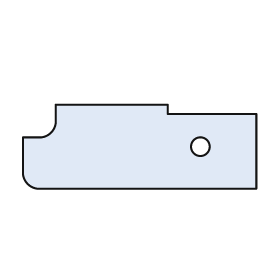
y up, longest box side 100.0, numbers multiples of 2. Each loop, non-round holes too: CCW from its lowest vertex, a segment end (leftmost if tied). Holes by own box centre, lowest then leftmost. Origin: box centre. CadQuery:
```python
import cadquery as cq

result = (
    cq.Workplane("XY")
    .moveTo(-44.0, -18.0)
    .lineTo(50.0, -18.0)
    .lineTo(50.0, 14.0)
    .lineTo(12.0, 14.0)
    .lineTo(12.0, 18.0)
    .lineTo(-36.0, 18.0)
    .lineTo(-36.0, 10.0)
    .threePointArc((-38.0, 6.0), (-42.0, 4.0))
    .lineTo(-50.0, 4.0)
    .lineTo(-50.0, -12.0)
    .threePointArc((-48.0, -16.0), (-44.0, -18.0))
    .close()
    .moveTo(26.0, 0.0)
    .circle(4.0)
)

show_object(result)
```